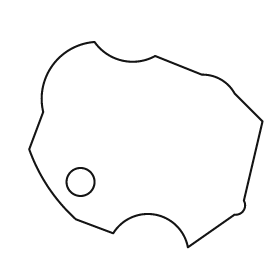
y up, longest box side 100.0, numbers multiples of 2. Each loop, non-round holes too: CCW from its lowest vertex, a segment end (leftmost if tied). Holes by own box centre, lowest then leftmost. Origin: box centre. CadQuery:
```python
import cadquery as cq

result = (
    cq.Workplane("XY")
    .moveTo(18.0, -44.0)
    .lineTo(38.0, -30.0)
    .threePointArc((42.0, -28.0), (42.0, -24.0))
    .lineTo(50.0, 10.0)
    .lineTo(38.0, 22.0)
    .threePointArc((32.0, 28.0), (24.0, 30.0))
    .lineTo(4.0, 38.0)
    .threePointArc((-10.0, 36.0), (-22.0, 44.0))
    .threePointArc((-40.0, 34.0), (-44.0, 14.0))
    .lineTo(-50.0, -2.0)
    .threePointArc((-42.0, -18.0), (-30.0, -32.0))
    .lineTo(-14.0, -38.0)
    .threePointArc((4.0, -30.0), (18.0, -44.0))
    .close()
    .moveTo(-28.0, -16.0)
    .circle(6.0)
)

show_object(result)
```